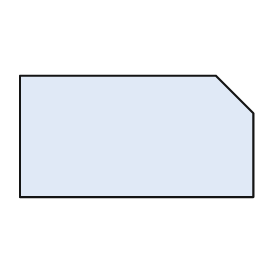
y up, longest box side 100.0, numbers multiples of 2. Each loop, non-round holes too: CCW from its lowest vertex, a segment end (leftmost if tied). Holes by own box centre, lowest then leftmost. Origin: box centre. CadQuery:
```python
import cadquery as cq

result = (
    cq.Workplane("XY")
    .moveTo(-50.0, -26.0)
    .lineTo(50.0, -26.0)
    .lineTo(50.0, 10.0)
    .lineTo(34.0, 26.0)
    .lineTo(-50.0, 26.0)
    .close()
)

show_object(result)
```